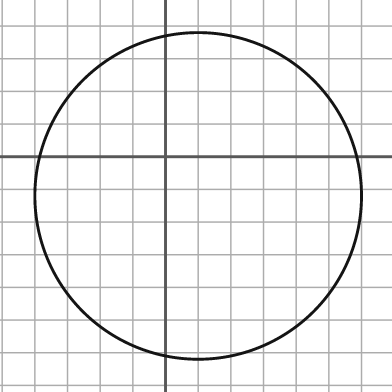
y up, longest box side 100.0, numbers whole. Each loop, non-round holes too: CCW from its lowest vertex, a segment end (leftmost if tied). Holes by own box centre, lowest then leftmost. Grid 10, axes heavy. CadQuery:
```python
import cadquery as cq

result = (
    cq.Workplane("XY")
    .moveTo(10.0, -12.0)
    .circle(50.0)
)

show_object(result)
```